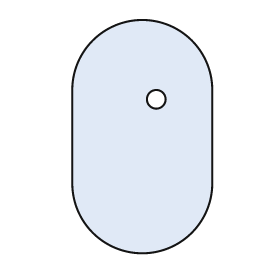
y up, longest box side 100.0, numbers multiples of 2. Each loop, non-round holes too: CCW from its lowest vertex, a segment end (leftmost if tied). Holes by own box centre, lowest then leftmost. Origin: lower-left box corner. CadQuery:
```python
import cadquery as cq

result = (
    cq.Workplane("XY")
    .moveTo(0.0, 30.0)
    .threePointArc((30.0, 0.0), (60.0, 30.0))
    .lineTo(60.0, 70.0)
    .threePointArc((30.0, 100.0), (0.0, 70.0))
    .close()
    .moveTo(36.0, 66.0)
    .circle(4.0)
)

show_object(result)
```